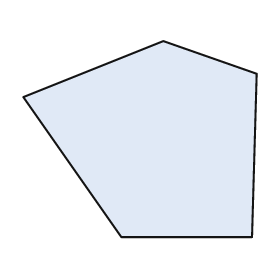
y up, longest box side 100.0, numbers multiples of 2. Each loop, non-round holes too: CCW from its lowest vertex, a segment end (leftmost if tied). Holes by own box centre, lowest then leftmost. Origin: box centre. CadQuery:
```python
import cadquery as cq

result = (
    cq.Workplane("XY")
    .moveTo(-8.0, -42.0)
    .lineTo(48.0, -42.0)
    .lineTo(50.0, 28.0)
    .lineTo(10.0, 42.0)
    .lineTo(-50.0, 18.0)
    .close()
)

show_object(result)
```